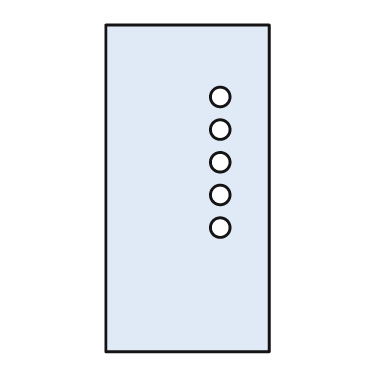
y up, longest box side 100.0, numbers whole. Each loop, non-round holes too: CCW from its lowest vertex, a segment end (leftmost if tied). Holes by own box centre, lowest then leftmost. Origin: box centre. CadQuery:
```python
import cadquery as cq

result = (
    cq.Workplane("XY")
    .moveTo(-25.0, -50.0)
    .lineTo(25.0, -50.0)
    .lineTo(25.0, 50.0)
    .lineTo(-25.0, 50.0)
    .close()
    .moveTo(10.0, -12.0)
    .circle(3.0)
    .moveTo(10.0, -2.0)
    .circle(3.0)
    .moveTo(10.0, 8.0)
    .circle(3.0)
    .moveTo(10.0, 18.0)
    .circle(3.0)
    .moveTo(10.0, 28.0)
    .circle(3.0)
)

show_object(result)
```